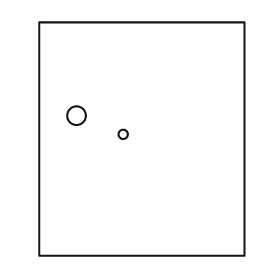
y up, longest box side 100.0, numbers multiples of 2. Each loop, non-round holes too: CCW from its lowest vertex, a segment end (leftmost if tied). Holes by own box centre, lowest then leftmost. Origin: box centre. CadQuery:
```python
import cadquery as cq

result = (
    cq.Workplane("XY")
    .moveTo(-44.0, -50.0)
    .lineTo(44.0, -50.0)
    .lineTo(44.0, 50.0)
    .lineTo(-44.0, 50.0)
    .close()
    .moveTo(-8.0, 2.0)
    .circle(2.0)
    .moveTo(-28.0, 10.0)
    .circle(4.0)
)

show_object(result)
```